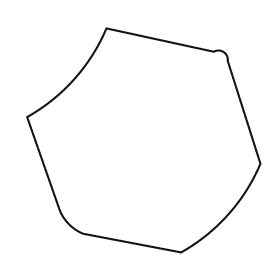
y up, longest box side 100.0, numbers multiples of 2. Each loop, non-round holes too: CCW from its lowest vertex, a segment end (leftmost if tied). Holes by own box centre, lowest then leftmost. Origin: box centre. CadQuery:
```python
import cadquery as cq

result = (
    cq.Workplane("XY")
    .moveTo(16.0, -48.0)
    .threePointArc((36.0, -32.0), (50.0, -10.0))
    .lineTo(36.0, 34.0)
    .threePointArc((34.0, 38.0), (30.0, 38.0))
    .lineTo(-16.0, 48.0)
    .threePointArc((-30.0, 26.0), (-50.0, 10.0))
    .lineTo(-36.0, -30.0)
    .threePointArc((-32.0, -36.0), (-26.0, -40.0))
    .close()
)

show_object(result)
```